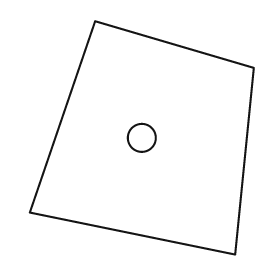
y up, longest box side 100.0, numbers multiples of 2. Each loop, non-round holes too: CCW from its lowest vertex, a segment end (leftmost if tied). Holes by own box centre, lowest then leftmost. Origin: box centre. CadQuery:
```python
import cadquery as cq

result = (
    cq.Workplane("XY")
    .moveTo(40.0, -50.0)
    .lineTo(48.0, 30.0)
    .lineTo(-20.0, 50.0)
    .lineTo(-48.0, -32.0)
    .close()
    .moveTo(0.0, 0.0)
    .circle(6.0)
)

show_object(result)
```